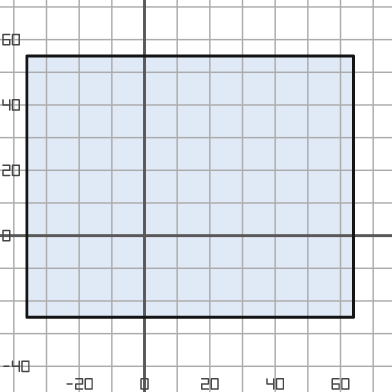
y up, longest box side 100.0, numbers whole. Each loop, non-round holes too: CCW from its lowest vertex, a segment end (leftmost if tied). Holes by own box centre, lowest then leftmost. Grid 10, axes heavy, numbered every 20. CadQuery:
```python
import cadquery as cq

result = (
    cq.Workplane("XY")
    .moveTo(-36.0, -25.0)
    .lineTo(64.0, -25.0)
    .lineTo(64.0, 55.0)
    .lineTo(-36.0, 55.0)
    .close()
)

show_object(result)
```